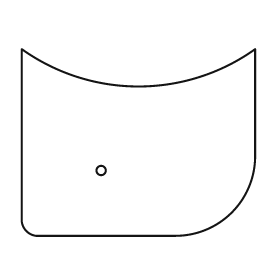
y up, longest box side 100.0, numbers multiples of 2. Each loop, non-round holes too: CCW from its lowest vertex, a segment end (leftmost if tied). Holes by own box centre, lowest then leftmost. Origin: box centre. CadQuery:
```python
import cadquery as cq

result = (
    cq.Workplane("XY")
    .moveTo(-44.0, -40.0)
    .lineTo(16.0, -40.0)
    .threePointArc((40.0, -30.0), (50.0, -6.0))
    .lineTo(50.0, 40.0)
    .threePointArc((0.0, 24.0), (-50.0, 40.0))
    .lineTo(-50.0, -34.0)
    .threePointArc((-48.0, -38.0), (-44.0, -40.0))
    .close()
    .moveTo(-16.0, -12.0)
    .circle(2.0)
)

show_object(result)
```